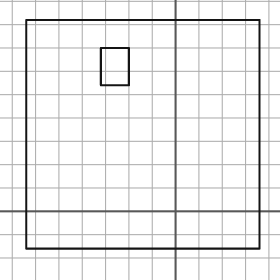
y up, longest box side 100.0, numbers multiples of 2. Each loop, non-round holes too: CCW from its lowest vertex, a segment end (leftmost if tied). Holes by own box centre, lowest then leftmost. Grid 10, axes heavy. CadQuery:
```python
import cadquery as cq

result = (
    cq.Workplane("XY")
    .moveTo(-64.0, -16.0)
    .lineTo(36.0, -16.0)
    .lineTo(36.0, 82.0)
    .lineTo(-64.0, 82.0)
    .close()
    .moveTo(-32.0, 54.0)
    .lineTo(-20.0, 54.0)
    .lineTo(-20.0, 70.0)
    .lineTo(-32.0, 70.0)
    .close()
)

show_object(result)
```